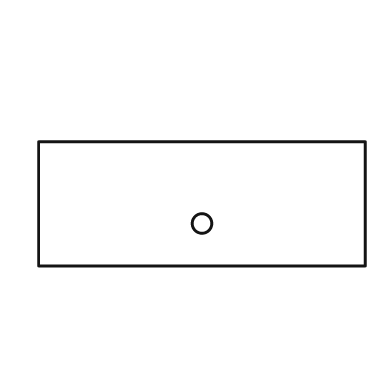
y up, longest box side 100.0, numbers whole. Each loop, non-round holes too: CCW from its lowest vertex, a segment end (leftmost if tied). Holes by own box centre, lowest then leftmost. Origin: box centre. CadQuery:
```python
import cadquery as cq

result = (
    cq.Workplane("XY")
    .moveTo(-50.0, -19.0)
    .lineTo(50.0, -19.0)
    .lineTo(50.0, 19.0)
    .lineTo(-50.0, 19.0)
    .close()
    .moveTo(0.0, -6.0)
    .circle(3.0)
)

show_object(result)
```